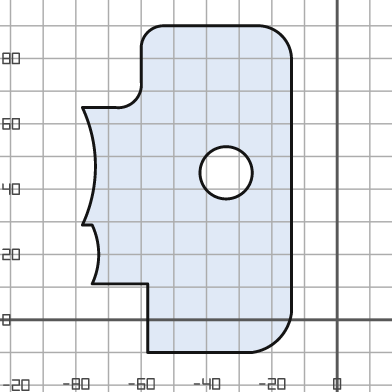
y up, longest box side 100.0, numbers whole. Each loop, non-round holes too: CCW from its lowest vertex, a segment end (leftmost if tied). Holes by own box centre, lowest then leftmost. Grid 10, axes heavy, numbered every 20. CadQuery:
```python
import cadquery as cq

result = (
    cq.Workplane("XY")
    .moveTo(-58.0, -10.0)
    .lineTo(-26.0, -10.0)
    .threePointArc((-18.0, -6.0), (-14.0, 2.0))
    .lineTo(-14.0, 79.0)
    .threePointArc((-17.0, 87.0), (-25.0, 90.0))
    .lineTo(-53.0, 90.0)
    .threePointArc((-58.0, 88.0), (-60.0, 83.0))
    .lineTo(-60.0, 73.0)
    .threePointArc((-62.0, 67.0), (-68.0, 65.0))
    .lineTo(-78.0, 65.0)
    .threePointArc((-74.0, 47.0), (-78.0, 29.0))
    .lineTo(-75.0, 29.0)
    .threePointArc((-73.0, 20.0), (-75.0, 11.0))
    .lineTo(-58.0, 11.0)
    .close()
    .moveTo(-34.0, 45.0)
    .circle(8.0)
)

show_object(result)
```